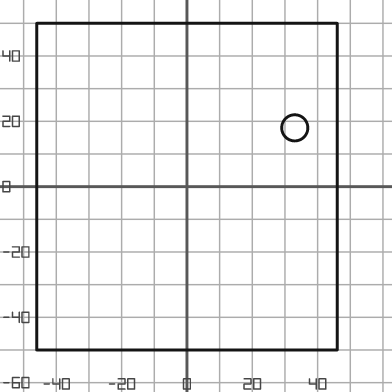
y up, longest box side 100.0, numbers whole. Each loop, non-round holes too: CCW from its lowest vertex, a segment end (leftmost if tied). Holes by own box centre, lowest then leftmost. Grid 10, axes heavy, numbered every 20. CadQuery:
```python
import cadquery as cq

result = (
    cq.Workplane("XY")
    .moveTo(-46.0, -50.0)
    .lineTo(46.0, -50.0)
    .lineTo(46.0, 50.0)
    .lineTo(-46.0, 50.0)
    .close()
    .moveTo(33.0, 18.0)
    .circle(4.0)
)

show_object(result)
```